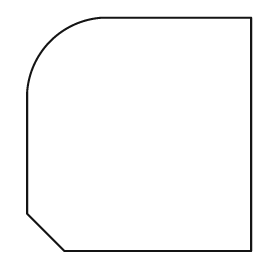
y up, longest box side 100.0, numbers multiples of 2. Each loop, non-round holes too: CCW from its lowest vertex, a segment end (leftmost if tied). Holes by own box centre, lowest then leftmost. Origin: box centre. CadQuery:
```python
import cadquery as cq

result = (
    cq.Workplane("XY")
    .moveTo(-32.0, -50.0)
    .lineTo(48.0, -50.0)
    .lineTo(48.0, 50.0)
    .lineTo(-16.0, 50.0)
    .threePointArc((-38.0, 40.0), (-48.0, 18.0))
    .lineTo(-48.0, -34.0)
    .close()
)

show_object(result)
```